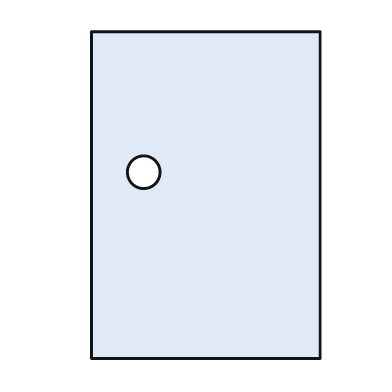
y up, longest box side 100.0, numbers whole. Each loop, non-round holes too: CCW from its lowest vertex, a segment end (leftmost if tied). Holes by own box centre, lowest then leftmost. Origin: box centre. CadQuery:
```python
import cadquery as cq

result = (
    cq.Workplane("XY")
    .moveTo(-35.0, -50.0)
    .lineTo(35.0, -50.0)
    .lineTo(35.0, 50.0)
    .lineTo(-35.0, 50.0)
    .close()
    .moveTo(-19.0, 7.0)
    .circle(5.0)
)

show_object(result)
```